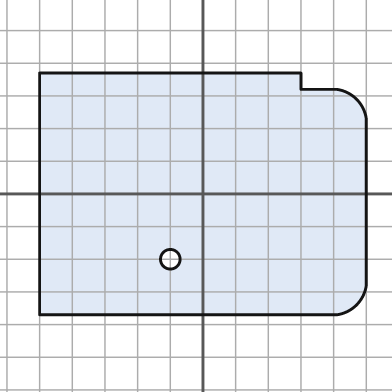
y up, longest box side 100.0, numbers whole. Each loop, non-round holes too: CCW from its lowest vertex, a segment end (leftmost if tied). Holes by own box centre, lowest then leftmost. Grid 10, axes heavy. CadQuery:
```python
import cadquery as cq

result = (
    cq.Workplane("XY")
    .moveTo(-50.0, -37.0)
    .lineTo(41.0, -37.0)
    .threePointArc((47.0, -34.0), (50.0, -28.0))
    .lineTo(50.0, 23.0)
    .threePointArc((47.0, 29.0), (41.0, 32.0))
    .lineTo(30.0, 32.0)
    .lineTo(30.0, 37.0)
    .lineTo(-50.0, 37.0)
    .close()
    .moveTo(-10.0, -20.0)
    .circle(3.0)
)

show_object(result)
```